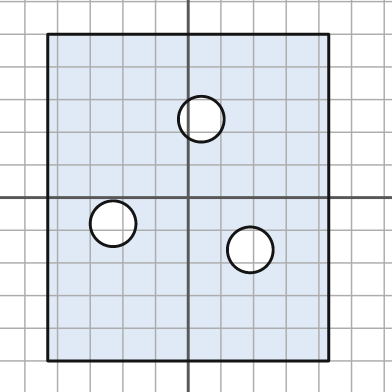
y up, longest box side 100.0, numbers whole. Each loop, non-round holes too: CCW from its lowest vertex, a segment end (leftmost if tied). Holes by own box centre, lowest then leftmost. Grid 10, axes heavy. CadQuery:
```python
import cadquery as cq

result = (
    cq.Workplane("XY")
    .moveTo(-43.0, -50.0)
    .lineTo(43.0, -50.0)
    .lineTo(43.0, 50.0)
    .lineTo(-43.0, 50.0)
    .close()
    .moveTo(19.0, -16.0)
    .circle(7.0)
    .moveTo(-23.0, -8.0)
    .circle(7.0)
    .moveTo(4.0, 24.0)
    .circle(7.0)
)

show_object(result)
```